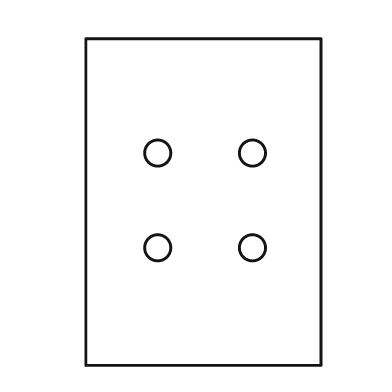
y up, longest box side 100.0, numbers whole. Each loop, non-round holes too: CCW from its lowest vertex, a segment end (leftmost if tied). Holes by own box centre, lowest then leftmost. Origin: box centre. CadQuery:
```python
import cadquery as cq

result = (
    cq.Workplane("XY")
    .moveTo(-36.0, -50.0)
    .lineTo(36.0, -50.0)
    .lineTo(36.0, 50.0)
    .lineTo(-36.0, 50.0)
    .close()
    .moveTo(-14.0, -14.0)
    .circle(4.0)
    .moveTo(15.0, -14.0)
    .circle(4.0)
    .moveTo(-14.0, 15.0)
    .circle(4.0)
    .moveTo(15.0, 15.0)
    .circle(4.0)
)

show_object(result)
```